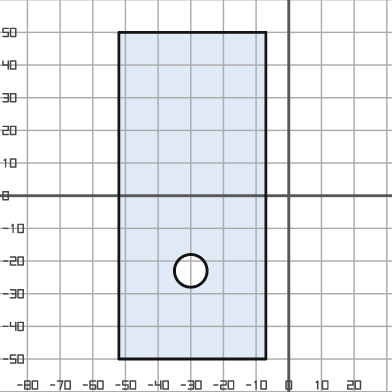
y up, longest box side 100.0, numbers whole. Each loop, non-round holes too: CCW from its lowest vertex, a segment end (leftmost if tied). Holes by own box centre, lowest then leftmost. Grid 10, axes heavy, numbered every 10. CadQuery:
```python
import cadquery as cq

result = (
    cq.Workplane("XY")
    .moveTo(-52.0, -50.0)
    .lineTo(-7.0, -50.0)
    .lineTo(-7.0, 50.0)
    .lineTo(-52.0, 50.0)
    .close()
    .moveTo(-30.0, -23.0)
    .circle(5.0)
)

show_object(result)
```